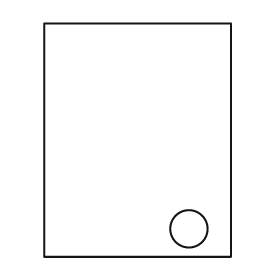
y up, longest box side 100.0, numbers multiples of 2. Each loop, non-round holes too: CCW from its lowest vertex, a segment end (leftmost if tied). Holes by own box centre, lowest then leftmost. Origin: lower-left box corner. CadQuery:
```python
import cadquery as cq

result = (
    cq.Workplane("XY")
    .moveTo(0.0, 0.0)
    .lineTo(80.0, 0.0)
    .lineTo(80.0, 100.0)
    .lineTo(0.0, 100.0)
    .close()
    .moveTo(62.0, 12.0)
    .circle(8.0)
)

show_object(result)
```